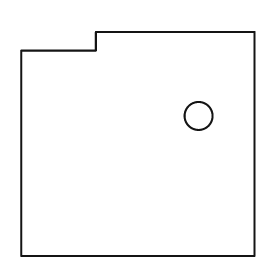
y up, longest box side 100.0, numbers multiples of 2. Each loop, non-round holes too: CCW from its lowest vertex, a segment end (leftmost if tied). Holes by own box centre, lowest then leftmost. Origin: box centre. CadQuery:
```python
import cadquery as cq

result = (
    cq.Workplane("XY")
    .moveTo(-50.0, -48.0)
    .lineTo(50.0, -48.0)
    .lineTo(50.0, 48.0)
    .lineTo(-18.0, 48.0)
    .lineTo(-18.0, 40.0)
    .lineTo(-50.0, 40.0)
    .close()
    .moveTo(26.0, 12.0)
    .circle(6.0)
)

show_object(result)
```